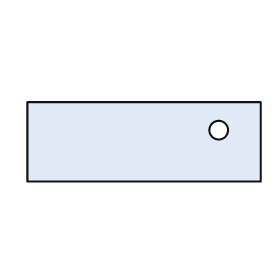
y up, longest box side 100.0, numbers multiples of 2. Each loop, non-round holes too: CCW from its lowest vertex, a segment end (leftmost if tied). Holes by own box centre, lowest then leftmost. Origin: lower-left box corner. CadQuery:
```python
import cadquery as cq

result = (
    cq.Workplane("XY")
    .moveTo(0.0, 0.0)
    .lineTo(100.0, 0.0)
    .lineTo(100.0, 34.0)
    .lineTo(0.0, 34.0)
    .close()
    .moveTo(82.0, 22.0)
    .circle(4.0)
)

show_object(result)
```